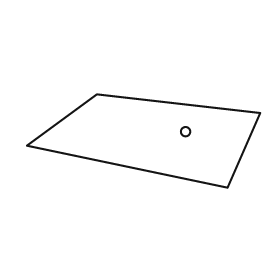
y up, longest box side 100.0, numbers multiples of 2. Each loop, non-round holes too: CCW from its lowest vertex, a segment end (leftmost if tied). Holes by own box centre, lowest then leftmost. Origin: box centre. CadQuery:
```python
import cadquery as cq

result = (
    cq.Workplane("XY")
    .moveTo(36.0, -20.0)
    .lineTo(50.0, 12.0)
    .lineTo(-20.0, 20.0)
    .lineTo(-50.0, -2.0)
    .close()
    .moveTo(18.0, 4.0)
    .circle(2.0)
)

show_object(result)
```